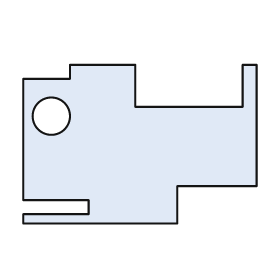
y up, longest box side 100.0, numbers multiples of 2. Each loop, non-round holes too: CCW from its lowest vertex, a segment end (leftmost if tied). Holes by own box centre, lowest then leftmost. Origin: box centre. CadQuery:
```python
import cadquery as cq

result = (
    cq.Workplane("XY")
    .moveTo(-50.0, -34.0)
    .lineTo(16.0, -34.0)
    .lineTo(16.0, -18.0)
    .lineTo(50.0, -18.0)
    .lineTo(50.0, 34.0)
    .lineTo(44.0, 34.0)
    .lineTo(44.0, 16.0)
    .lineTo(-2.0, 16.0)
    .lineTo(-2.0, 34.0)
    .lineTo(-30.0, 34.0)
    .lineTo(-30.0, 28.0)
    .lineTo(-50.0, 28.0)
    .lineTo(-50.0, -24.0)
    .lineTo(-22.0, -24.0)
    .lineTo(-22.0, -30.0)
    .lineTo(-50.0, -30.0)
    .close()
    .moveTo(-38.0, 12.0)
    .circle(8.0)
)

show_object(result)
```